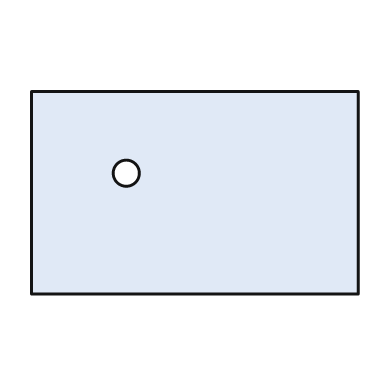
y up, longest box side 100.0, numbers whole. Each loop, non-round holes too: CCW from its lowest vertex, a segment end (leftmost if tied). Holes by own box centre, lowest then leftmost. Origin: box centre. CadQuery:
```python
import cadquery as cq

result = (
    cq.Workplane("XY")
    .moveTo(-50.0, -31.0)
    .lineTo(50.0, -31.0)
    .lineTo(50.0, 31.0)
    .lineTo(-50.0, 31.0)
    .close()
    .moveTo(-21.0, 6.0)
    .circle(4.0)
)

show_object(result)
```